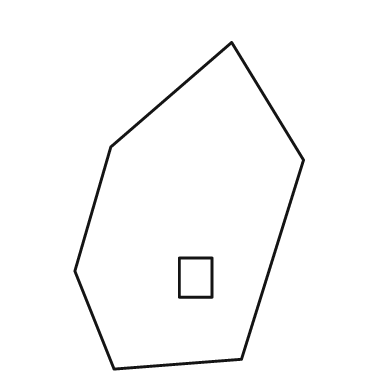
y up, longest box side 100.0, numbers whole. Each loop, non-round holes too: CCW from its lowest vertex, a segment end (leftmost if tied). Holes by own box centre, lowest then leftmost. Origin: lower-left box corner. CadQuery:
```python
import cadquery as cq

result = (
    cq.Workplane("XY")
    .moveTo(12.0, 0.0)
    .lineTo(51.0, 3.0)
    .lineTo(70.0, 64.0)
    .lineTo(48.0, 100.0)
    .lineTo(11.0, 68.0)
    .lineTo(0.0, 30.0)
    .close()
    .moveTo(32.0, 22.0)
    .lineTo(42.0, 22.0)
    .lineTo(42.0, 34.0)
    .lineTo(32.0, 34.0)
    .close()
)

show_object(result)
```